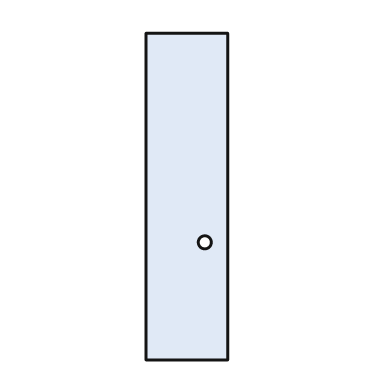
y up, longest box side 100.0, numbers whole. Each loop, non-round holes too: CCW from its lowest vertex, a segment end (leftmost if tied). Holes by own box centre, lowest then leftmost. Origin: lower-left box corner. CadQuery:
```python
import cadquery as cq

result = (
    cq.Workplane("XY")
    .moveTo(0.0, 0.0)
    .lineTo(25.0, 0.0)
    .lineTo(25.0, 100.0)
    .lineTo(0.0, 100.0)
    .close()
    .moveTo(18.0, 36.0)
    .circle(2.0)
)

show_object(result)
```